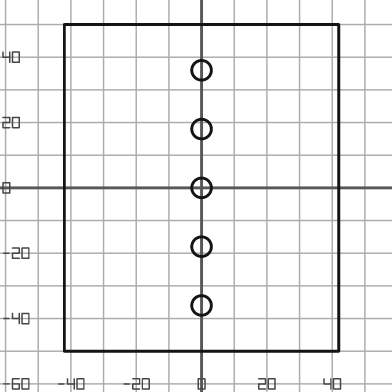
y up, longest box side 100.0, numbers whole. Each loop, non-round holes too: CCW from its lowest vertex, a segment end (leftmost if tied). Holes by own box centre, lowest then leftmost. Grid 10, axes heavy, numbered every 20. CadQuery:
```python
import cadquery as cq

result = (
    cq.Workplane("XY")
    .moveTo(-42.0, -50.0)
    .lineTo(42.0, -50.0)
    .lineTo(42.0, 50.0)
    .lineTo(-42.0, 50.0)
    .close()
    .moveTo(0.0, -36.0)
    .circle(3.0)
    .moveTo(0.0, -18.0)
    .circle(3.0)
    .moveTo(0.0, 0.0)
    .circle(3.0)
    .moveTo(0.0, 18.0)
    .circle(3.0)
    .moveTo(0.0, 36.0)
    .circle(3.0)
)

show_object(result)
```